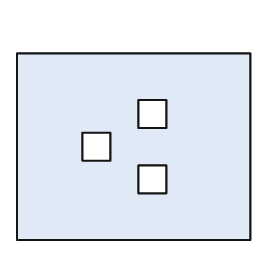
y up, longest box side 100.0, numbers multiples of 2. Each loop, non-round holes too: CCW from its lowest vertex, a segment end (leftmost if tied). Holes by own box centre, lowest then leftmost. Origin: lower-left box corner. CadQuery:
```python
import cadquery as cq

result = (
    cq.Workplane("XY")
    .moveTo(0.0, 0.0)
    .lineTo(100.0, 0.0)
    .lineTo(100.0, 80.0)
    .lineTo(0.0, 80.0)
    .close()
    .moveTo(52.0, 20.0)
    .lineTo(64.0, 20.0)
    .lineTo(64.0, 32.0)
    .lineTo(52.0, 32.0)
    .close()
    .moveTo(28.0, 34.0)
    .lineTo(40.0, 34.0)
    .lineTo(40.0, 46.0)
    .lineTo(28.0, 46.0)
    .close()
    .moveTo(52.0, 48.0)
    .lineTo(64.0, 48.0)
    .lineTo(64.0, 60.0)
    .lineTo(52.0, 60.0)
    .close()
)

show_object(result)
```